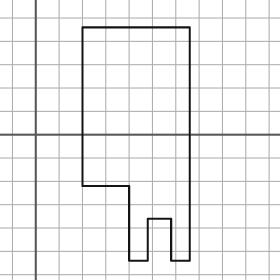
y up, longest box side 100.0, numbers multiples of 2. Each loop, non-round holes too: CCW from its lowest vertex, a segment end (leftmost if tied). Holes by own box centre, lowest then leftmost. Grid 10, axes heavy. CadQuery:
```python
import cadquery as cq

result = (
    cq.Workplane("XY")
    .moveTo(40.0, -54.0)
    .lineTo(48.0, -54.0)
    .lineTo(48.0, -36.0)
    .lineTo(58.0, -36.0)
    .lineTo(58.0, -54.0)
    .lineTo(66.0, -54.0)
    .lineTo(66.0, 46.0)
    .lineTo(20.0, 46.0)
    .lineTo(20.0, -22.0)
    .lineTo(40.0, -22.0)
    .close()
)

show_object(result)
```